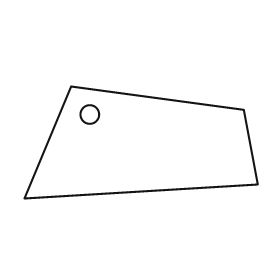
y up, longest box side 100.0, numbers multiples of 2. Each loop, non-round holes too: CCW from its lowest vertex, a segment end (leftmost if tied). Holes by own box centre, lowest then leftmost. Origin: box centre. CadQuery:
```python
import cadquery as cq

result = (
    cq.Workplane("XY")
    .moveTo(-50.0, -24.0)
    .lineTo(50.0, -18.0)
    .lineTo(44.0, 14.0)
    .lineTo(-30.0, 24.0)
    .close()
    .moveTo(-22.0, 12.0)
    .circle(4.0)
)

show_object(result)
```